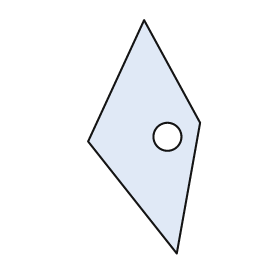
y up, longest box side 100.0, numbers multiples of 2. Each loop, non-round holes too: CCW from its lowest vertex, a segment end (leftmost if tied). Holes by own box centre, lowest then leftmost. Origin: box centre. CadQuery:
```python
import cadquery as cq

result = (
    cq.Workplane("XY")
    .moveTo(14.0, -50.0)
    .lineTo(24.0, 6.0)
    .lineTo(0.0, 50.0)
    .lineTo(-24.0, -2.0)
    .close()
    .moveTo(10.0, 0.0)
    .circle(6.0)
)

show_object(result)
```